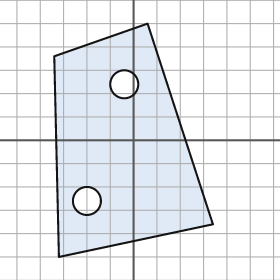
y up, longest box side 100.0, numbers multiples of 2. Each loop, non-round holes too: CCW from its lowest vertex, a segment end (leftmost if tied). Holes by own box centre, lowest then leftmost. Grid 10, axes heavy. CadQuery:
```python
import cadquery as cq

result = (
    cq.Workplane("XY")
    .moveTo(-32.0, -50.0)
    .lineTo(34.0, -36.0)
    .lineTo(6.0, 50.0)
    .lineTo(-34.0, 36.0)
    .close()
    .moveTo(-20.0, -26.0)
    .circle(6.0)
    .moveTo(-4.0, 24.0)
    .circle(6.0)
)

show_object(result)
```